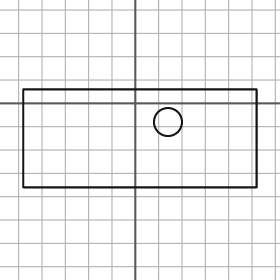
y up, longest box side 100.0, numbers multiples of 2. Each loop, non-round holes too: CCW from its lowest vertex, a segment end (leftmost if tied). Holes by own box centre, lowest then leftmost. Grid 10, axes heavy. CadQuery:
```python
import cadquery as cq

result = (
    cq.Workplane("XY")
    .moveTo(-48.0, -36.0)
    .lineTo(52.0, -36.0)
    .lineTo(52.0, 6.0)
    .lineTo(-48.0, 6.0)
    .close()
    .moveTo(14.0, -8.0)
    .circle(6.0)
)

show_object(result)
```